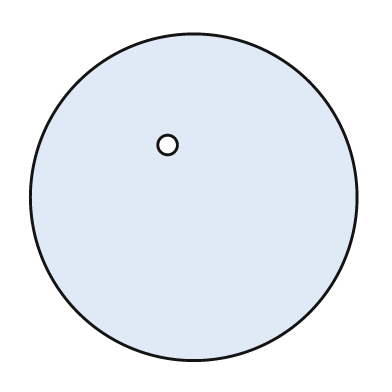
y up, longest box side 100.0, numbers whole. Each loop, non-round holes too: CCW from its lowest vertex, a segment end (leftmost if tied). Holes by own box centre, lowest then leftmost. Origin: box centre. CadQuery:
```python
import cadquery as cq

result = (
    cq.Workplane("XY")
    .moveTo(0.0, 0.0)
    .circle(50.0)
    .moveTo(-8.0, 16.0)
    .circle(3.0)
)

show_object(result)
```